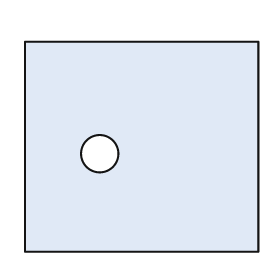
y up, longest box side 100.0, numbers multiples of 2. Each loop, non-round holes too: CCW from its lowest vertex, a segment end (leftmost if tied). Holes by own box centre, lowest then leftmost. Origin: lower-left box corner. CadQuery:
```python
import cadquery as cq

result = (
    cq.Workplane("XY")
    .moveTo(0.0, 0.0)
    .lineTo(100.0, 0.0)
    .lineTo(100.0, 90.0)
    .lineTo(0.0, 90.0)
    .close()
    .moveTo(32.0, 42.0)
    .circle(8.0)
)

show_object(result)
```